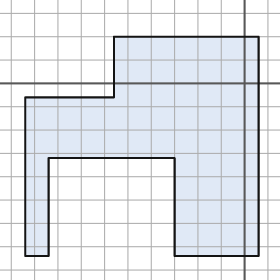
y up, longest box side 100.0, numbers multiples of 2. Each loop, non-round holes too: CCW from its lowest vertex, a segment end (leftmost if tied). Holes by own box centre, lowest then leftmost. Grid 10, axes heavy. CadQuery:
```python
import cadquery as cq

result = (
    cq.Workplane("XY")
    .moveTo(-94.0, -74.0)
    .lineTo(-84.0, -74.0)
    .lineTo(-84.0, -32.0)
    .lineTo(-30.0, -32.0)
    .lineTo(-30.0, -74.0)
    .lineTo(6.0, -74.0)
    .lineTo(6.0, 20.0)
    .lineTo(-56.0, 20.0)
    .lineTo(-56.0, -6.0)
    .lineTo(-94.0, -6.0)
    .close()
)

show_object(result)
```